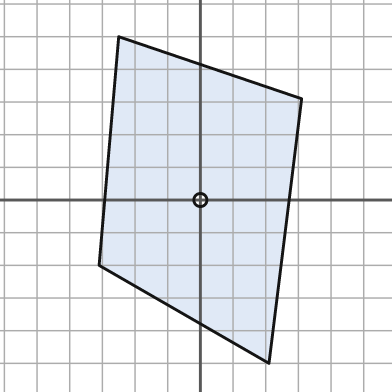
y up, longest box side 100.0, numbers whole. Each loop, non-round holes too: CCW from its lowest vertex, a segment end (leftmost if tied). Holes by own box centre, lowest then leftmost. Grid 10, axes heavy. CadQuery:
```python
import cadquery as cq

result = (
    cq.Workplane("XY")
    .moveTo(21.0, -50.0)
    .lineTo(31.0, 31.0)
    .lineTo(-25.0, 50.0)
    .lineTo(-31.0, -20.0)
    .close()
    .moveTo(0.0, 0.0)
    .circle(2.0)
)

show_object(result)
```